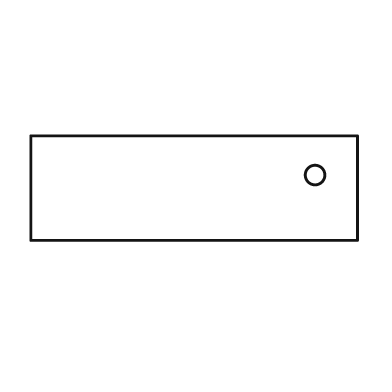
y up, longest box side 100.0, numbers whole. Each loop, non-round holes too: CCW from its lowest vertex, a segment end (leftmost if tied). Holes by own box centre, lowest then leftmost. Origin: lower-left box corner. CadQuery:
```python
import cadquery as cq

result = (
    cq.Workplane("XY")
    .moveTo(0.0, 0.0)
    .lineTo(100.0, 0.0)
    .lineTo(100.0, 32.0)
    .lineTo(0.0, 32.0)
    .close()
    .moveTo(87.0, 20.0)
    .circle(3.0)
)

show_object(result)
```